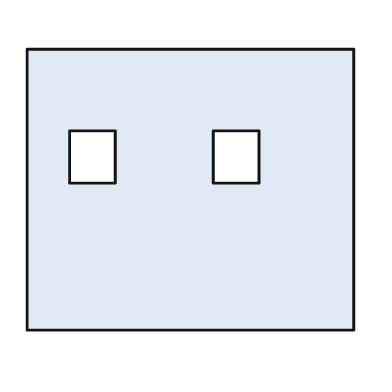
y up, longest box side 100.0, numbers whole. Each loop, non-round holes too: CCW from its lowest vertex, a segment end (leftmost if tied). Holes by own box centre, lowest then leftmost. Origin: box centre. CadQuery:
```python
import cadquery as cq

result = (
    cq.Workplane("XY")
    .moveTo(-50.0, -43.0)
    .lineTo(50.0, -43.0)
    .lineTo(50.0, 43.0)
    .lineTo(-50.0, 43.0)
    .close()
    .moveTo(-37.0, 2.0)
    .lineTo(-23.0, 2.0)
    .lineTo(-23.0, 18.0)
    .lineTo(-37.0, 18.0)
    .close()
    .moveTo(7.0, 2.0)
    .lineTo(21.0, 2.0)
    .lineTo(21.0, 18.0)
    .lineTo(7.0, 18.0)
    .close()
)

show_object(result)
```